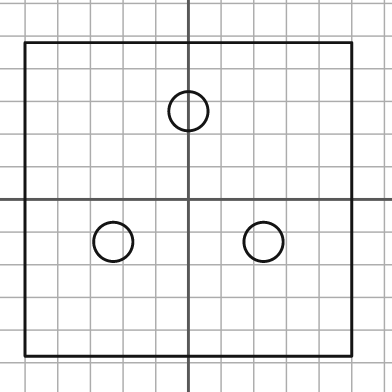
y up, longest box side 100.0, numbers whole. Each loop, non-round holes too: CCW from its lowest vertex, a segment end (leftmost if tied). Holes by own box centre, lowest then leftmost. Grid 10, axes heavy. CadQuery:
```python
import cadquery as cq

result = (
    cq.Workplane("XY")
    .moveTo(-50.0, -48.0)
    .lineTo(50.0, -48.0)
    .lineTo(50.0, 48.0)
    .lineTo(-50.0, 48.0)
    .close()
    .moveTo(-23.0, -13.0)
    .circle(6.0)
    .moveTo(23.0, -13.0)
    .circle(6.0)
    .moveTo(0.0, 27.0)
    .circle(6.0)
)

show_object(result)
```